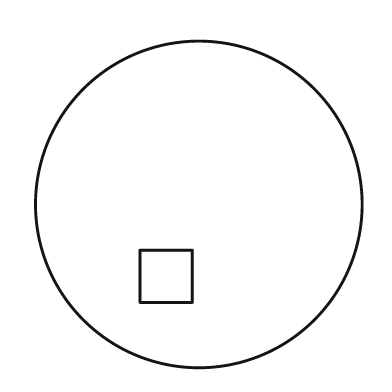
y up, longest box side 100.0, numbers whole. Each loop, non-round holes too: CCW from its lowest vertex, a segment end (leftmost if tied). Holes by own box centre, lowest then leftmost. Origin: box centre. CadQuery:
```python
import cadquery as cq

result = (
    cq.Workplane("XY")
    .moveTo(0.0, 0.0)
    .circle(50.0)
    .moveTo(-18.0, -30.0)
    .lineTo(-2.0, -30.0)
    .lineTo(-2.0, -14.0)
    .lineTo(-18.0, -14.0)
    .close()
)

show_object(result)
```